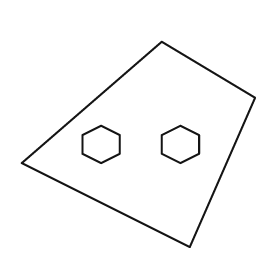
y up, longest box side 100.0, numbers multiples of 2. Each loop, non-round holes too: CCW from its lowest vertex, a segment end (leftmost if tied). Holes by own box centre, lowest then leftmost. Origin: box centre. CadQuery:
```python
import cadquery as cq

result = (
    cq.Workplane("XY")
    .moveTo(22.0, -44.0)
    .lineTo(50.0, 20.0)
    .lineTo(10.0, 44.0)
    .lineTo(-50.0, -8.0)
    .close()
    .moveTo(-16.0, -8.0)
    .lineTo(-8.0, -4.0)
    .lineTo(-8.0, 4.0)
    .lineTo(-16.0, 8.0)
    .lineTo(-24.0, 4.0)
    .lineTo(-24.0, -4.0)
    .close()
    .moveTo(18.0, -8.0)
    .lineTo(26.0, -4.0)
    .lineTo(26.0, 4.0)
    .lineTo(18.0, 8.0)
    .lineTo(10.0, 4.0)
    .lineTo(10.0, -4.0)
    .close()
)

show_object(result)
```